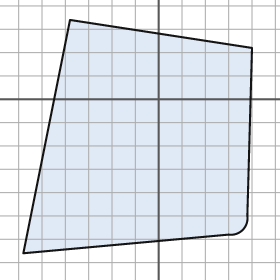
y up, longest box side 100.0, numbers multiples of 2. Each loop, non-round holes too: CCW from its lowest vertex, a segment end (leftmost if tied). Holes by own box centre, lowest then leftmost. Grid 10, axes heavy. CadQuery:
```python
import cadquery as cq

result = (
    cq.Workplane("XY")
    .moveTo(-58.0, -66.0)
    .lineTo(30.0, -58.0)
    .threePointArc((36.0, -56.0), (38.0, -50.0))
    .lineTo(40.0, 22.0)
    .lineTo(-38.0, 34.0)
    .close()
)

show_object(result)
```